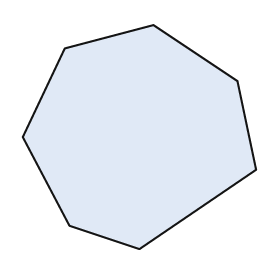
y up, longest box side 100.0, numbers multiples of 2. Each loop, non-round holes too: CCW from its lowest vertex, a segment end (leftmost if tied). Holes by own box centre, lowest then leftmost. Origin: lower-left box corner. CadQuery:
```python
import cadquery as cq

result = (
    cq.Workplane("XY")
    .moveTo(50.0, 0.0)
    .lineTo(100.0, 34.0)
    .lineTo(92.0, 72.0)
    .lineTo(56.0, 96.0)
    .lineTo(18.0, 86.0)
    .lineTo(0.0, 48.0)
    .lineTo(20.0, 10.0)
    .close()
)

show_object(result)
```